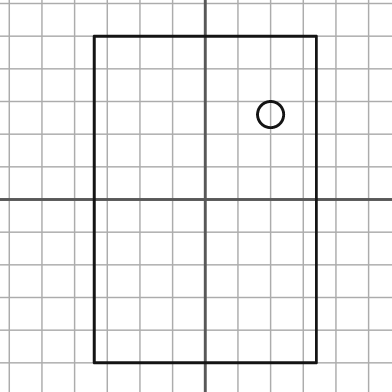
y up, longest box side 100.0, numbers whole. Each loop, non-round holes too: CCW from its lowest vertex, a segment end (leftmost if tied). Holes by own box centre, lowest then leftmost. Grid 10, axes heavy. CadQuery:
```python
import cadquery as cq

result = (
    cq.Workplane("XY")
    .moveTo(-34.0, -50.0)
    .lineTo(34.0, -50.0)
    .lineTo(34.0, 50.0)
    .lineTo(-34.0, 50.0)
    .close()
    .moveTo(20.0, 26.0)
    .circle(4.0)
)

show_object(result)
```